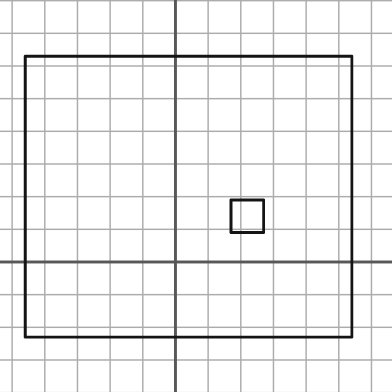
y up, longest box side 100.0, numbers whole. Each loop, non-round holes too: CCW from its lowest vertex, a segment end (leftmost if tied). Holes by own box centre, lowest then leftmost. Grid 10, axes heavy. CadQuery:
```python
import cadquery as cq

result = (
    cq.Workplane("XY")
    .moveTo(-46.0, -23.0)
    .lineTo(54.0, -23.0)
    .lineTo(54.0, 63.0)
    .lineTo(-46.0, 63.0)
    .close()
    .moveTo(17.0, 9.0)
    .lineTo(27.0, 9.0)
    .lineTo(27.0, 19.0)
    .lineTo(17.0, 19.0)
    .close()
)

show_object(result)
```